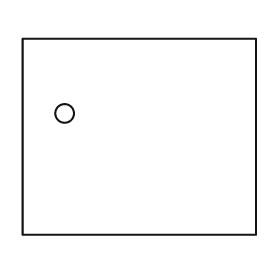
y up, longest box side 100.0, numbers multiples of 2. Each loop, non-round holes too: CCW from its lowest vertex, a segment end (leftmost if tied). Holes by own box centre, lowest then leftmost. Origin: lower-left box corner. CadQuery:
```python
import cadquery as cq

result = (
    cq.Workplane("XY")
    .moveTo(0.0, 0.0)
    .lineTo(100.0, 0.0)
    .lineTo(100.0, 84.0)
    .lineTo(0.0, 84.0)
    .close()
    .moveTo(18.0, 52.0)
    .circle(4.0)
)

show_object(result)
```